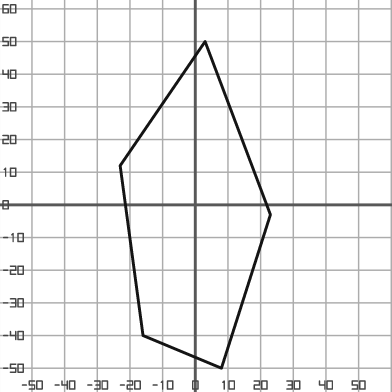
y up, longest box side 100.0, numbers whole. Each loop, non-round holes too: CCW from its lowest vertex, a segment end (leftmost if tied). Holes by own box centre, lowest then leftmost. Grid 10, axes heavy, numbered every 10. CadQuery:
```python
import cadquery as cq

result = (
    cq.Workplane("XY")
    .moveTo(8.0, -50.0)
    .lineTo(23.0, -3.0)
    .lineTo(3.0, 50.0)
    .lineTo(-23.0, 12.0)
    .lineTo(-16.0, -40.0)
    .close()
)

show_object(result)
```